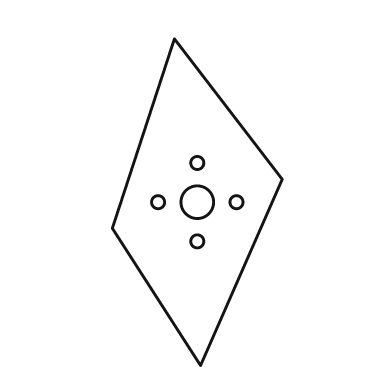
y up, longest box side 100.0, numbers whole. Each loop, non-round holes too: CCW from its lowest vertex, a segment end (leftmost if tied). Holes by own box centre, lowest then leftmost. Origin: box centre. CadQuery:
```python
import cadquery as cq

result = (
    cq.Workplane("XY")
    .moveTo(1.0, -50.0)
    .lineTo(26.0, 7.0)
    .lineTo(-7.0, 50.0)
    .lineTo(-26.0, -8.0)
    .close()
    .moveTo(0.0, -12.0)
    .circle(2.0)
    .moveTo(-12.0, 0.0)
    .circle(2.0)
    .moveTo(0.0, 0.0)
    .circle(5.0)
    .moveTo(12.0, 0.0)
    .circle(2.0)
    .moveTo(0.0, 12.0)
    .circle(2.0)
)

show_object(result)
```